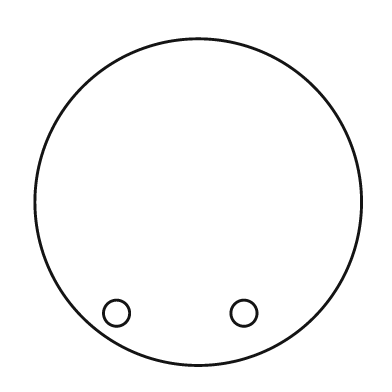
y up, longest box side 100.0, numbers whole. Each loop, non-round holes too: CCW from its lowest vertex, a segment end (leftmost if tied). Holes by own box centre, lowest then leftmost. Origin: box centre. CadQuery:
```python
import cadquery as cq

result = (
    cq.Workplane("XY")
    .moveTo(0.0, 0.0)
    .circle(50.0)
    .moveTo(-25.0, -34.0)
    .circle(4.0)
    .moveTo(14.0, -34.0)
    .circle(4.0)
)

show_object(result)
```